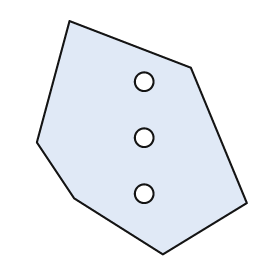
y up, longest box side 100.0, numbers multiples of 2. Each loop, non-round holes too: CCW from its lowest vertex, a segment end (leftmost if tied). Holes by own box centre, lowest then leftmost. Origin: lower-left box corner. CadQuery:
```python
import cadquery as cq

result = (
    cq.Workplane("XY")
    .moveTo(54.0, 0.0)
    .lineTo(90.0, 22.0)
    .lineTo(66.0, 80.0)
    .lineTo(14.0, 100.0)
    .lineTo(0.0, 48.0)
    .lineTo(16.0, 24.0)
    .close()
    .moveTo(46.0, 26.0)
    .circle(4.0)
    .moveTo(46.0, 50.0)
    .circle(4.0)
    .moveTo(46.0, 74.0)
    .circle(4.0)
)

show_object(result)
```